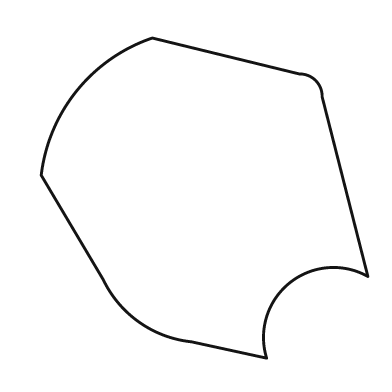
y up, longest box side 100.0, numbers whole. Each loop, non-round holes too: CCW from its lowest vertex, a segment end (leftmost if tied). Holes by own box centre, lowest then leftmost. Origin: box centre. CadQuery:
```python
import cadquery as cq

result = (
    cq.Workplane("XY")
    .moveTo(19.0, -49.0)
    .threePointArc((26.0, -26.0), (50.0, -24.0))
    .lineTo(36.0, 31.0)
    .threePointArc((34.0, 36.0), (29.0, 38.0))
    .lineTo(-16.0, 49.0)
    .threePointArc((-39.0, 33.0), (-50.0, 7.0))
    .lineTo(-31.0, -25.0)
    .threePointArc((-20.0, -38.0), (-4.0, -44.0))
    .close()
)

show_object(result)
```